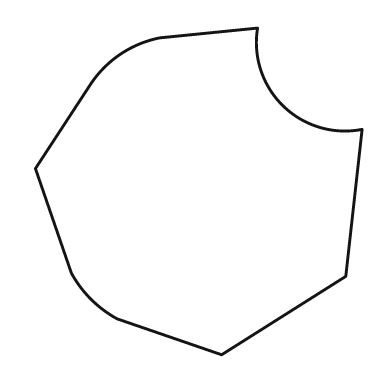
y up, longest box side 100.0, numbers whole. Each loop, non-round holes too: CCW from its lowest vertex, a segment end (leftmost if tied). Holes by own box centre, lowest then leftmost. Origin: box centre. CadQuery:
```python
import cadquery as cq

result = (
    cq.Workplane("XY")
    .moveTo(7.0, -50.0)
    .lineTo(45.0, -26.0)
    .lineTo(50.0, 19.0)
    .threePointArc((26.0, 26.0), (18.0, 50.0))
    .lineTo(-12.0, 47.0)
    .threePointArc((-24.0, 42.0), (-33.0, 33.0))
    .lineTo(-50.0, 7.0)
    .lineTo(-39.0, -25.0)
    .threePointArc((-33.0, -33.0), (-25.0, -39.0))
    .close()
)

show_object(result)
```